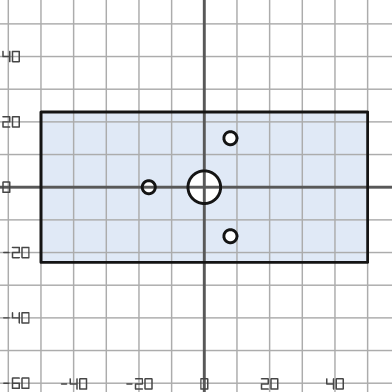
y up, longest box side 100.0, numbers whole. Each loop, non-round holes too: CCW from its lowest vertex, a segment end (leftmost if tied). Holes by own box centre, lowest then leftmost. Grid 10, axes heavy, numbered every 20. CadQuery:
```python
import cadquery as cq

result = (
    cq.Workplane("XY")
    .moveTo(-50.0, -23.0)
    .lineTo(50.0, -23.0)
    .lineTo(50.0, 23.0)
    .lineTo(-50.0, 23.0)
    .close()
    .moveTo(8.0, -15.0)
    .circle(2.0)
    .moveTo(-17.0, 0.0)
    .circle(2.0)
    .moveTo(0.0, 0.0)
    .circle(5.0)
    .moveTo(8.0, 15.0)
    .circle(2.0)
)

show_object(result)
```